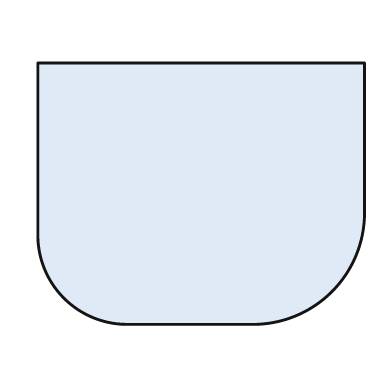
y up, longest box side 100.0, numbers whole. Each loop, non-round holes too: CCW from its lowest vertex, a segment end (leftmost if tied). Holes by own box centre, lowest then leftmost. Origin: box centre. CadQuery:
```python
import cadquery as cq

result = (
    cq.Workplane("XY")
    .moveTo(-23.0, -40.0)
    .lineTo(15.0, -40.0)
    .threePointArc((40.0, -30.0), (50.0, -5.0))
    .lineTo(50.0, 40.0)
    .lineTo(-50.0, 40.0)
    .lineTo(-50.0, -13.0)
    .threePointArc((-42.0, -32.0), (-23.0, -40.0))
    .close()
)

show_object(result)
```